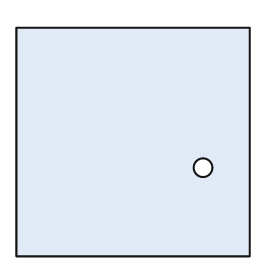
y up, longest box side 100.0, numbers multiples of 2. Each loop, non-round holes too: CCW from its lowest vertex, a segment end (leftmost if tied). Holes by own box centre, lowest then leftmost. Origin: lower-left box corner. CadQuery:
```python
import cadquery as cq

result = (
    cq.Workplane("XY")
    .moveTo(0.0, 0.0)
    .lineTo(100.0, 0.0)
    .lineTo(100.0, 98.0)
    .lineTo(0.0, 98.0)
    .close()
    .moveTo(80.0, 38.0)
    .circle(4.0)
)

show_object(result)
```